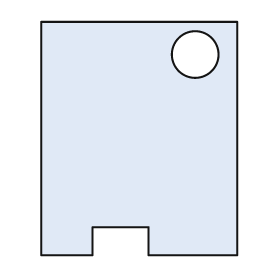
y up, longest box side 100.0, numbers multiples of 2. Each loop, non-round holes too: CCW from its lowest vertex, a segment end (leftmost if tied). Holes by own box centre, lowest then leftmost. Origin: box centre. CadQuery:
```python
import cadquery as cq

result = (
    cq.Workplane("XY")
    .moveTo(-42.0, -50.0)
    .lineTo(-20.0, -50.0)
    .lineTo(-20.0, -38.0)
    .lineTo(4.0, -38.0)
    .lineTo(4.0, -50.0)
    .lineTo(42.0, -50.0)
    .lineTo(42.0, 50.0)
    .lineTo(-42.0, 50.0)
    .close()
    .moveTo(24.0, 36.0)
    .circle(10.0)
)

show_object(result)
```